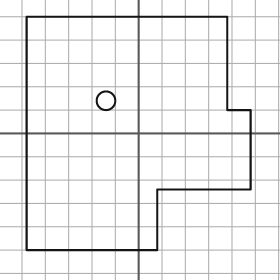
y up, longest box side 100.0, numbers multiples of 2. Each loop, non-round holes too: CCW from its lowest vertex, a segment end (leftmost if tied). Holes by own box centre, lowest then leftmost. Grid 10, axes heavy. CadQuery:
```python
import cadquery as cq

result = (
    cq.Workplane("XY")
    .moveTo(-48.0, -50.0)
    .lineTo(8.0, -50.0)
    .lineTo(8.0, -24.0)
    .lineTo(48.0, -24.0)
    .lineTo(48.0, 10.0)
    .lineTo(38.0, 10.0)
    .lineTo(38.0, 50.0)
    .lineTo(-48.0, 50.0)
    .close()
    .moveTo(-14.0, 14.0)
    .circle(4.0)
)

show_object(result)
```